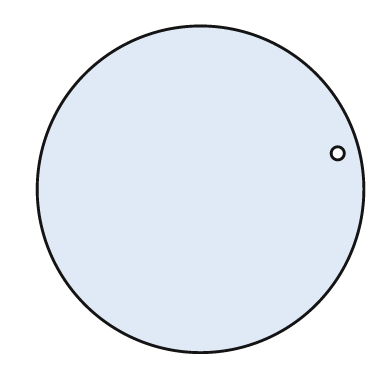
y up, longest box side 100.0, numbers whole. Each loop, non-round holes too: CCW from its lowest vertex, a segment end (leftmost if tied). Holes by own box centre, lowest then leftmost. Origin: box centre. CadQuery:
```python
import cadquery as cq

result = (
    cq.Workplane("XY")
    .moveTo(0.0, 0.0)
    .circle(50.0)
    .moveTo(42.0, 11.0)
    .circle(2.0)
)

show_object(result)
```